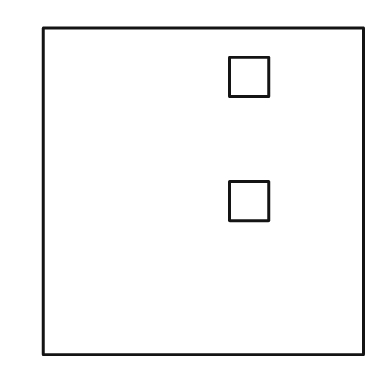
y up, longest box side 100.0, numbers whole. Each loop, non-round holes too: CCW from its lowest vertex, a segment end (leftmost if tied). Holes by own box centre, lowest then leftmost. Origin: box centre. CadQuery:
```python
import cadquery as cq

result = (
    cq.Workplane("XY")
    .moveTo(-49.0, -50.0)
    .lineTo(49.0, -50.0)
    .lineTo(49.0, 50.0)
    .lineTo(-49.0, 50.0)
    .close()
    .moveTo(8.0, -9.0)
    .lineTo(20.0, -9.0)
    .lineTo(20.0, 3.0)
    .lineTo(8.0, 3.0)
    .close()
    .moveTo(8.0, 29.0)
    .lineTo(20.0, 29.0)
    .lineTo(20.0, 41.0)
    .lineTo(8.0, 41.0)
    .close()
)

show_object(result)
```